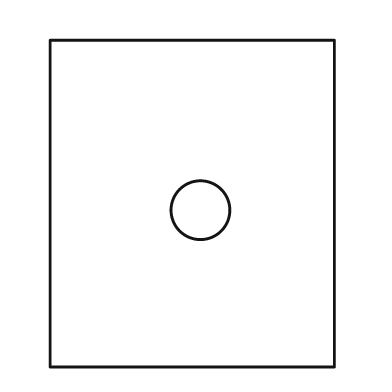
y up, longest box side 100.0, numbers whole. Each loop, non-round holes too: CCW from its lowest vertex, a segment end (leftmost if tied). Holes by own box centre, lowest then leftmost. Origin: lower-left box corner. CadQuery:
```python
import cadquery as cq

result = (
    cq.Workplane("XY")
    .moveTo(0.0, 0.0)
    .lineTo(87.0, 0.0)
    .lineTo(87.0, 100.0)
    .lineTo(0.0, 100.0)
    .close()
    .moveTo(46.0, 48.0)
    .circle(9.0)
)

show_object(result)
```